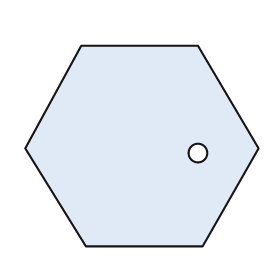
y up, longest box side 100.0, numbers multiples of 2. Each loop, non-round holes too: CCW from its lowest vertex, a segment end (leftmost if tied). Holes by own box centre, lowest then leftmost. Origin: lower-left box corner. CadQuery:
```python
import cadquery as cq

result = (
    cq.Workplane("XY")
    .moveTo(26.0, 0.0)
    .lineTo(76.0, 0.0)
    .lineTo(100.0, 42.0)
    .lineTo(74.0, 86.0)
    .lineTo(24.0, 86.0)
    .lineTo(0.0, 42.0)
    .close()
    .moveTo(74.0, 40.0)
    .circle(4.0)
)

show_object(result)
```